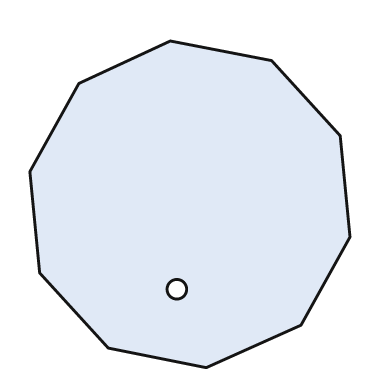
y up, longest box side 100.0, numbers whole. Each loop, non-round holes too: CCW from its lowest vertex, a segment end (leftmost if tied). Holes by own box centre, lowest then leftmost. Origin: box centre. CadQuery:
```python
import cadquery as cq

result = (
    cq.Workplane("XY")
    .moveTo(5.0, -50.0)
    .lineTo(34.0, -37.0)
    .lineTo(49.0, -10.0)
    .lineTo(46.0, 21.0)
    .lineTo(25.0, 44.0)
    .lineTo(-6.0, 50.0)
    .lineTo(-34.0, 37.0)
    .lineTo(-49.0, 10.0)
    .lineTo(-46.0, -21.0)
    .lineTo(-25.0, -44.0)
    .close()
    .moveTo(-4.0, -26.0)
    .circle(3.0)
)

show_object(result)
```